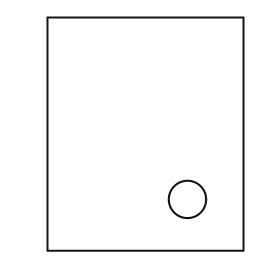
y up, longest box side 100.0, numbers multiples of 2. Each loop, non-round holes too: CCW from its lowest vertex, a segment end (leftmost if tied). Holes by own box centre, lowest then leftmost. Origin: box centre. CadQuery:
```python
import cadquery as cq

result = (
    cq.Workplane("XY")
    .moveTo(-42.0, -50.0)
    .lineTo(42.0, -50.0)
    .lineTo(42.0, 50.0)
    .lineTo(-42.0, 50.0)
    .close()
    .moveTo(18.0, -28.0)
    .circle(8.0)
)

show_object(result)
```